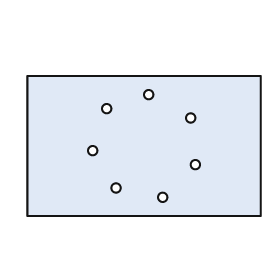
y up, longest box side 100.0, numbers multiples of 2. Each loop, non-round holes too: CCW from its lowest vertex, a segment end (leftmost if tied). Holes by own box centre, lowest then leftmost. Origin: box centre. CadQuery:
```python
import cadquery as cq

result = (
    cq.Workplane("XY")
    .moveTo(-50.0, -30.0)
    .lineTo(50.0, -30.0)
    .lineTo(50.0, 30.0)
    .lineTo(-50.0, 30.0)
    .close()
    .moveTo(8.0, -22.0)
    .circle(2.0)
    .moveTo(-12.0, -18.0)
    .circle(2.0)
    .moveTo(22.0, -8.0)
    .circle(2.0)
    .moveTo(-22.0, -2.0)
    .circle(2.0)
    .moveTo(20.0, 12.0)
    .circle(2.0)
    .moveTo(-16.0, 16.0)
    .circle(2.0)
    .moveTo(2.0, 22.0)
    .circle(2.0)
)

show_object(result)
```